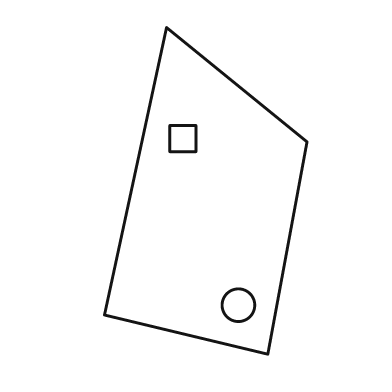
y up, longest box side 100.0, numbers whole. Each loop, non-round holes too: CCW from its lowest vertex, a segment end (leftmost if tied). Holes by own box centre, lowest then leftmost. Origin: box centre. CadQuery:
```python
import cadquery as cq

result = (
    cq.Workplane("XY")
    .moveTo(19.0, -50.0)
    .lineTo(31.0, 15.0)
    .lineTo(-12.0, 50.0)
    .lineTo(-31.0, -38.0)
    .close()
    .moveTo(10.0, -35.0)
    .circle(5.0)
    .moveTo(-11.0, 12.0)
    .lineTo(-3.0, 12.0)
    .lineTo(-3.0, 20.0)
    .lineTo(-11.0, 20.0)
    .close()
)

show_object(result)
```